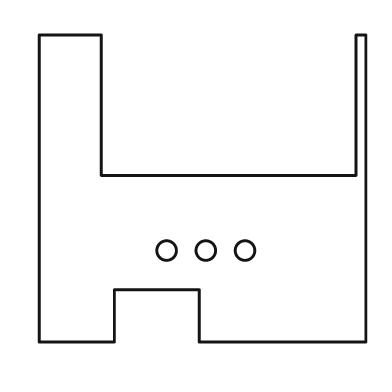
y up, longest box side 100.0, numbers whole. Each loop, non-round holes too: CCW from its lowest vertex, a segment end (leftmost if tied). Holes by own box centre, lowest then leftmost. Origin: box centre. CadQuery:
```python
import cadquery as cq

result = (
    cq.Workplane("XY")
    .moveTo(-50.0, -47.0)
    .lineTo(-27.0, -47.0)
    .lineTo(-27.0, -31.0)
    .lineTo(-1.0, -31.0)
    .lineTo(-1.0, -47.0)
    .lineTo(50.0, -47.0)
    .lineTo(50.0, 47.0)
    .lineTo(47.0, 47.0)
    .lineTo(47.0, 4.0)
    .lineTo(-31.0, 4.0)
    .lineTo(-31.0, 47.0)
    .lineTo(-50.0, 47.0)
    .close()
    .moveTo(-11.0, -19.0)
    .circle(3.0)
    .moveTo(1.0, -19.0)
    .circle(3.0)
    .moveTo(13.0, -19.0)
    .circle(3.0)
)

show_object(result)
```